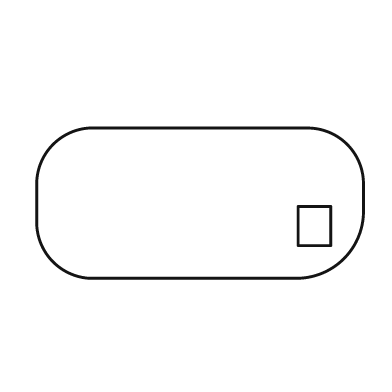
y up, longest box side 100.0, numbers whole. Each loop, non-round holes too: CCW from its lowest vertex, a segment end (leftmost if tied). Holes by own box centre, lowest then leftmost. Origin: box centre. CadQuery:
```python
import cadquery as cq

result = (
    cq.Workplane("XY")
    .moveTo(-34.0, -23.0)
    .lineTo(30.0, -23.0)
    .threePointArc((44.0, -17.0), (50.0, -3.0))
    .lineTo(50.0, 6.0)
    .threePointArc((45.0, 18.0), (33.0, 23.0))
    .lineTo(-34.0, 23.0)
    .threePointArc((-45.0, 18.0), (-50.0, 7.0))
    .lineTo(-50.0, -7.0)
    .threePointArc((-45.0, -18.0), (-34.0, -23.0))
    .close()
    .moveTo(30.0, -13.0)
    .lineTo(40.0, -13.0)
    .lineTo(40.0, -1.0)
    .lineTo(30.0, -1.0)
    .close()
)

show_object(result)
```